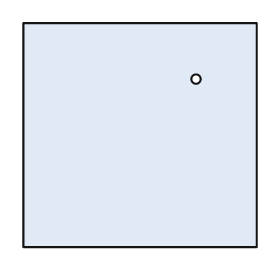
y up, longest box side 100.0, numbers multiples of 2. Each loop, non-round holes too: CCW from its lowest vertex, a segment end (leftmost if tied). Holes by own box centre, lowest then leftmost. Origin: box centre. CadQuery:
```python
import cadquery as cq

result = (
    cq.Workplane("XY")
    .moveTo(-50.0, -48.0)
    .lineTo(50.0, -48.0)
    .lineTo(50.0, 48.0)
    .lineTo(-50.0, 48.0)
    .close()
    .moveTo(24.0, 24.0)
    .circle(2.0)
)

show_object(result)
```